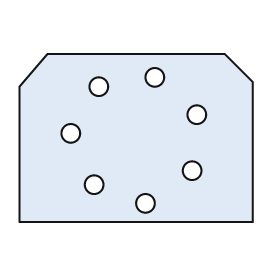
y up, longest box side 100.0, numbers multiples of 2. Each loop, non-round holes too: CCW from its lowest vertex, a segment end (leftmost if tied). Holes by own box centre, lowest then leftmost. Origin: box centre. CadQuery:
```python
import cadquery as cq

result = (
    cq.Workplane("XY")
    .moveTo(-50.0, -36.0)
    .lineTo(50.0, -36.0)
    .lineTo(50.0, 24.0)
    .lineTo(38.0, 36.0)
    .lineTo(-38.0, 36.0)
    .lineTo(-50.0, 22.0)
    .close()
    .moveTo(4.0, -28.0)
    .circle(4.0)
    .moveTo(-18.0, -20.0)
    .circle(4.0)
    .moveTo(24.0, -14.0)
    .circle(4.0)
    .moveTo(-28.0, 2.0)
    .circle(4.0)
    .moveTo(26.0, 10.0)
    .circle(4.0)
    .moveTo(-16.0, 22.0)
    .circle(4.0)
    .moveTo(8.0, 26.0)
    .circle(4.0)
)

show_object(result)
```